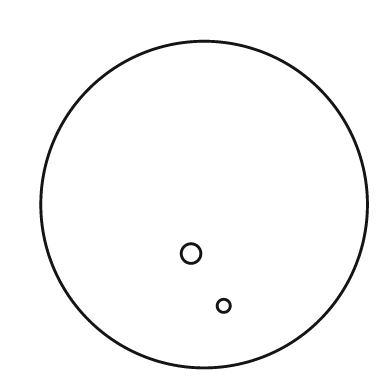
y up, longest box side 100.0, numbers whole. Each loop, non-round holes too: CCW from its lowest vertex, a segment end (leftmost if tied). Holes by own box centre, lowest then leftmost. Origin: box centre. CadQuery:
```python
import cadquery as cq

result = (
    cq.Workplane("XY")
    .moveTo(0.0, 0.0)
    .circle(50.0)
    .moveTo(6.0, -31.0)
    .circle(2.0)
    .moveTo(-4.0, -15.0)
    .circle(3.0)
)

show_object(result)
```